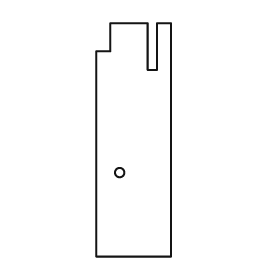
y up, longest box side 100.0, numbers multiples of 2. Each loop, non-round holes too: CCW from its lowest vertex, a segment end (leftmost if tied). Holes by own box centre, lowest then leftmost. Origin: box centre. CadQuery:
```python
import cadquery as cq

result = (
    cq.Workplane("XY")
    .moveTo(-16.0, -50.0)
    .lineTo(16.0, -50.0)
    .lineTo(16.0, 50.0)
    .lineTo(10.0, 50.0)
    .lineTo(10.0, 30.0)
    .lineTo(6.0, 30.0)
    .lineTo(6.0, 50.0)
    .lineTo(-10.0, 50.0)
    .lineTo(-10.0, 38.0)
    .lineTo(-16.0, 38.0)
    .close()
    .moveTo(-6.0, -14.0)
    .circle(2.0)
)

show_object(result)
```